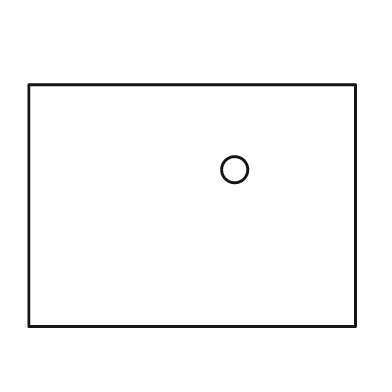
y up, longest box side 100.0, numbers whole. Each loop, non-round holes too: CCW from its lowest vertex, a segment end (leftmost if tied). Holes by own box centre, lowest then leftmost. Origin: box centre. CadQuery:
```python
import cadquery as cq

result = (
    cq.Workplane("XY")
    .moveTo(-50.0, -37.0)
    .lineTo(50.0, -37.0)
    .lineTo(50.0, 37.0)
    .lineTo(-50.0, 37.0)
    .close()
    .moveTo(13.0, 11.0)
    .circle(4.0)
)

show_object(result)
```